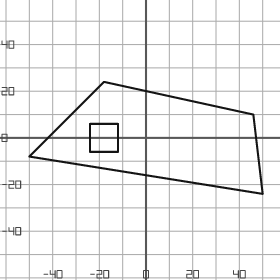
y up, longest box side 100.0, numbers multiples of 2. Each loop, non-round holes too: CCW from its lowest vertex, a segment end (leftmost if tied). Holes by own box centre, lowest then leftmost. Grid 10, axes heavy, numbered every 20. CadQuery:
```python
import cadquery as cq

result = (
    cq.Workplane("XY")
    .moveTo(50.0, -24.0)
    .lineTo(46.0, 10.0)
    .lineTo(-18.0, 24.0)
    .lineTo(-50.0, -8.0)
    .close()
    .moveTo(-24.0, -6.0)
    .lineTo(-12.0, -6.0)
    .lineTo(-12.0, 6.0)
    .lineTo(-24.0, 6.0)
    .close()
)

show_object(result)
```